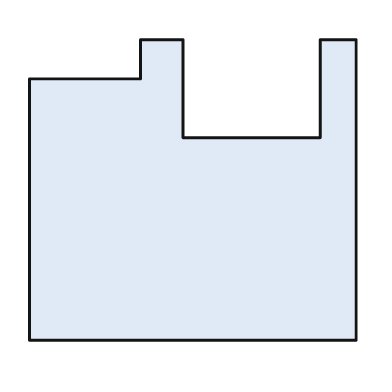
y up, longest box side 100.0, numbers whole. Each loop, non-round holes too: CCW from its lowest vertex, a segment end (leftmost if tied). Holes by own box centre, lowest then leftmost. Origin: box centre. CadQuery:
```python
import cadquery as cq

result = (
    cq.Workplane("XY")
    .moveTo(-50.0, -46.0)
    .lineTo(50.0, -46.0)
    .lineTo(50.0, 46.0)
    .lineTo(39.0, 46.0)
    .lineTo(39.0, 16.0)
    .lineTo(-3.0, 16.0)
    .lineTo(-3.0, 46.0)
    .lineTo(-16.0, 46.0)
    .lineTo(-16.0, 34.0)
    .lineTo(-50.0, 34.0)
    .close()
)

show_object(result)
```